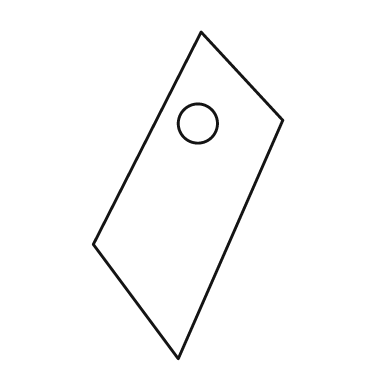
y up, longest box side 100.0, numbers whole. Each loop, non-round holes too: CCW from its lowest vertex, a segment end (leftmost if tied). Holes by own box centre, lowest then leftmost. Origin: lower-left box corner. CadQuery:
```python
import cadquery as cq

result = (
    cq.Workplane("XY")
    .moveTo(26.0, 0.0)
    .lineTo(58.0, 73.0)
    .lineTo(33.0, 100.0)
    .lineTo(0.0, 35.0)
    .close()
    .moveTo(32.0, 72.0)
    .circle(6.0)
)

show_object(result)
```